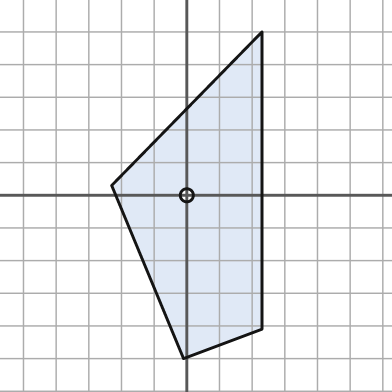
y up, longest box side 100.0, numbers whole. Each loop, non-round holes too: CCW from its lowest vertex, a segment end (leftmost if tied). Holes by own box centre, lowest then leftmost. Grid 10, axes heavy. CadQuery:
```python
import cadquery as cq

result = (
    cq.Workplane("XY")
    .moveTo(-1.0, -50.0)
    .lineTo(23.0, -41.0)
    .lineTo(23.0, 50.0)
    .lineTo(-23.0, 3.0)
    .close()
    .moveTo(0.0, 0.0)
    .circle(2.0)
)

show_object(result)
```